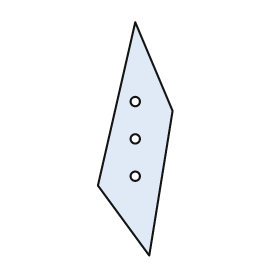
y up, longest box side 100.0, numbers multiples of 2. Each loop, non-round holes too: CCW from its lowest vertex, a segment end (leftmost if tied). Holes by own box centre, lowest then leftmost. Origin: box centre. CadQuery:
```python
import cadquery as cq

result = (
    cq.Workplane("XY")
    .moveTo(6.0, -50.0)
    .lineTo(16.0, 12.0)
    .lineTo(0.0, 50.0)
    .lineTo(-16.0, -20.0)
    .close()
    .moveTo(0.0, -16.0)
    .circle(2.0)
    .moveTo(0.0, 0.0)
    .circle(2.0)
    .moveTo(0.0, 16.0)
    .circle(2.0)
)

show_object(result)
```